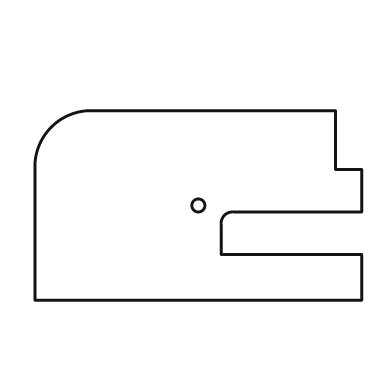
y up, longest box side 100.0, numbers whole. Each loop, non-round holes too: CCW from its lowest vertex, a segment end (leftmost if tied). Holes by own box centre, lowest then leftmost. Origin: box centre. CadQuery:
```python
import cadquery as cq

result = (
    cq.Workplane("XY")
    .moveTo(-50.0, -29.0)
    .lineTo(50.0, -29.0)
    .lineTo(50.0, -15.0)
    .lineTo(7.0, -15.0)
    .lineTo(7.0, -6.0)
    .threePointArc((8.0, -3.0), (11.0, -2.0))
    .lineTo(50.0, -2.0)
    .lineTo(50.0, 11.0)
    .lineTo(42.0, 11.0)
    .lineTo(42.0, 29.0)
    .lineTo(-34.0, 29.0)
    .threePointArc((-45.0, 24.0), (-50.0, 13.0))
    .close()
    .moveTo(0.0, 0.0)
    .circle(2.0)
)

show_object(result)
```